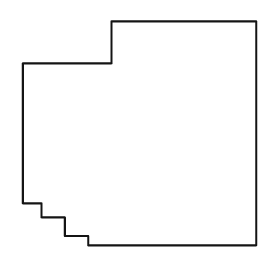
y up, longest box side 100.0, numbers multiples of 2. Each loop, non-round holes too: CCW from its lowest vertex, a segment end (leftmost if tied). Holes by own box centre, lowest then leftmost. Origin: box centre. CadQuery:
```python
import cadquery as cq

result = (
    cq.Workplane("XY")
    .moveTo(-22.0, -48.0)
    .lineTo(50.0, -48.0)
    .lineTo(50.0, 48.0)
    .lineTo(-12.0, 48.0)
    .lineTo(-12.0, 30.0)
    .lineTo(-50.0, 30.0)
    .lineTo(-50.0, -30.0)
    .lineTo(-42.0, -30.0)
    .lineTo(-42.0, -36.0)
    .lineTo(-32.0, -36.0)
    .lineTo(-32.0, -44.0)
    .lineTo(-22.0, -44.0)
    .close()
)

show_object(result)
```